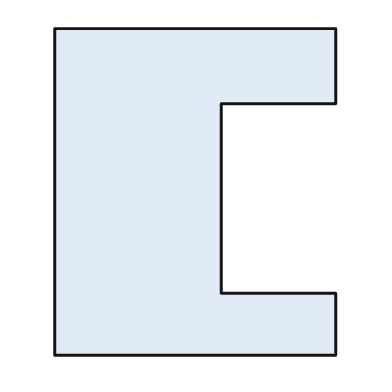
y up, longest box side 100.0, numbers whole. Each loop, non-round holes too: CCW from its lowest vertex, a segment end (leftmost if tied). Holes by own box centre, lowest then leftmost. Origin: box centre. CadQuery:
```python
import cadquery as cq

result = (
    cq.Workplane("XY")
    .moveTo(-43.0, -50.0)
    .lineTo(43.0, -50.0)
    .lineTo(43.0, -31.0)
    .lineTo(8.0, -31.0)
    .lineTo(8.0, 27.0)
    .lineTo(43.0, 27.0)
    .lineTo(43.0, 50.0)
    .lineTo(-43.0, 50.0)
    .close()
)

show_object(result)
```